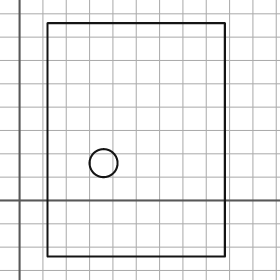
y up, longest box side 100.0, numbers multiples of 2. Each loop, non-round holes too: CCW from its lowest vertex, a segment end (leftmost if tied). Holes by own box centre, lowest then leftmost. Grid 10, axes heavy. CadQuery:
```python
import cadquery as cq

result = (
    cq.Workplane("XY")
    .moveTo(12.0, -24.0)
    .lineTo(88.0, -24.0)
    .lineTo(88.0, 76.0)
    .lineTo(12.0, 76.0)
    .close()
    .moveTo(36.0, 16.0)
    .circle(6.0)
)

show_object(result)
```